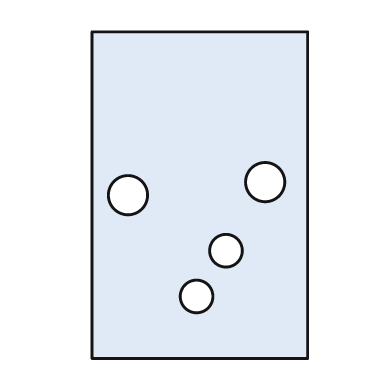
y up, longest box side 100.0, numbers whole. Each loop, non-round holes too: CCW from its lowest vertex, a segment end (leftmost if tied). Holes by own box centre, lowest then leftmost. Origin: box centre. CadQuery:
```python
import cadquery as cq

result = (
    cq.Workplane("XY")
    .moveTo(-33.0, -50.0)
    .lineTo(33.0, -50.0)
    .lineTo(33.0, 50.0)
    .lineTo(-33.0, 50.0)
    .close()
    .moveTo(-1.0, -31.0)
    .circle(5.0)
    .moveTo(8.0, -17.0)
    .circle(5.0)
    .moveTo(-22.0, 0.0)
    .circle(6.0)
    .moveTo(20.0, 4.0)
    .circle(6.0)
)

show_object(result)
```